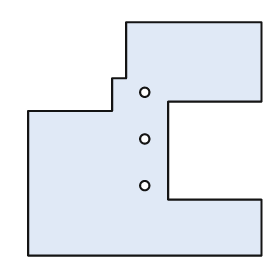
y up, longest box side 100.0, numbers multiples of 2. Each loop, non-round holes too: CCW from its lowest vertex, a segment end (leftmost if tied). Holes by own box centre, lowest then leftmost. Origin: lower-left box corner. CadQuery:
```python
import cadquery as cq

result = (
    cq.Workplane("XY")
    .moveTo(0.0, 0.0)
    .lineTo(100.0, 0.0)
    .lineTo(100.0, 24.0)
    .lineTo(60.0, 24.0)
    .lineTo(60.0, 66.0)
    .lineTo(100.0, 66.0)
    .lineTo(100.0, 100.0)
    .lineTo(42.0, 100.0)
    .lineTo(42.0, 76.0)
    .lineTo(36.0, 76.0)
    .lineTo(36.0, 62.0)
    .lineTo(0.0, 62.0)
    .close()
    .moveTo(50.0, 30.0)
    .circle(2.0)
    .moveTo(50.0, 50.0)
    .circle(2.0)
    .moveTo(50.0, 70.0)
    .circle(2.0)
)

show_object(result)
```